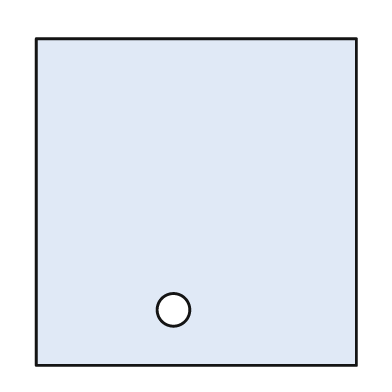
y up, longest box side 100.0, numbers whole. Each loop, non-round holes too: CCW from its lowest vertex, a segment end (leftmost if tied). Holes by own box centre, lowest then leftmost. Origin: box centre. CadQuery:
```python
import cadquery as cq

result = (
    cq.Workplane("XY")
    .moveTo(-49.0, -50.0)
    .lineTo(49.0, -50.0)
    .lineTo(49.0, 50.0)
    .lineTo(-49.0, 50.0)
    .close()
    .moveTo(-7.0, -33.0)
    .circle(5.0)
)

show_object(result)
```